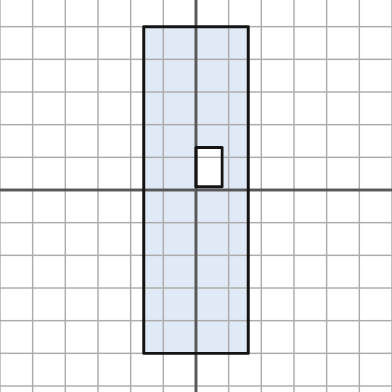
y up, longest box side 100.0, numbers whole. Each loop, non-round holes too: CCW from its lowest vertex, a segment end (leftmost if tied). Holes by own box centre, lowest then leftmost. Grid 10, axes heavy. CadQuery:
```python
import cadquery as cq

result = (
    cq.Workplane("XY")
    .moveTo(-16.0, -50.0)
    .lineTo(16.0, -50.0)
    .lineTo(16.0, 50.0)
    .lineTo(-16.0, 50.0)
    .close()
    .moveTo(0.0, 1.0)
    .lineTo(8.0, 1.0)
    .lineTo(8.0, 13.0)
    .lineTo(0.0, 13.0)
    .close()
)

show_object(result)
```